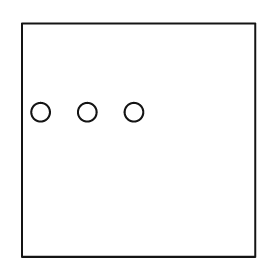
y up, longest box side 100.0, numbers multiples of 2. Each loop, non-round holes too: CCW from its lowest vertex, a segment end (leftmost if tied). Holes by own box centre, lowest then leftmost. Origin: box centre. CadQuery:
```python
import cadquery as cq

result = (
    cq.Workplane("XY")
    .moveTo(-50.0, -50.0)
    .lineTo(50.0, -50.0)
    .lineTo(50.0, 50.0)
    .lineTo(-50.0, 50.0)
    .close()
    .moveTo(-42.0, 12.0)
    .circle(4.0)
    .moveTo(-22.0, 12.0)
    .circle(4.0)
    .moveTo(-2.0, 12.0)
    .circle(4.0)
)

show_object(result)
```